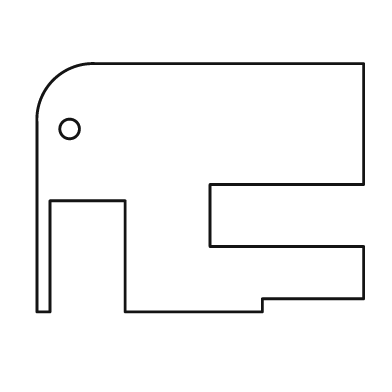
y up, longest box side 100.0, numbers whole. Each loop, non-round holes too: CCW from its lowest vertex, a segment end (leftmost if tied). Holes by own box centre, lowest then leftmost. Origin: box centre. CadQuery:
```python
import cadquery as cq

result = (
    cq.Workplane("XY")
    .moveTo(-50.0, -38.0)
    .lineTo(-46.0, -38.0)
    .lineTo(-46.0, -4.0)
    .lineTo(-23.0, -4.0)
    .lineTo(-23.0, -38.0)
    .lineTo(19.0, -38.0)
    .lineTo(19.0, -34.0)
    .lineTo(50.0, -34.0)
    .lineTo(50.0, -18.0)
    .lineTo(3.0, -18.0)
    .lineTo(3.0, 1.0)
    .lineTo(50.0, 1.0)
    .lineTo(50.0, 38.0)
    .lineTo(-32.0, 38.0)
    .threePointArc((-45.0, 33.0), (-50.0, 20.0))
    .close()
    .moveTo(-40.0, 18.0)
    .circle(3.0)
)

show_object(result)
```